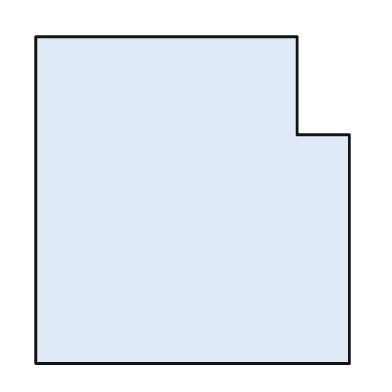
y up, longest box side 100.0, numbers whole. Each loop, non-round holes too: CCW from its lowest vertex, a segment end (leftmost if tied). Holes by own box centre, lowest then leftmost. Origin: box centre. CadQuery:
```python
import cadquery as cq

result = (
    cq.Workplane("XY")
    .moveTo(-48.0, -50.0)
    .lineTo(48.0, -50.0)
    .lineTo(48.0, 20.0)
    .lineTo(32.0, 20.0)
    .lineTo(32.0, 50.0)
    .lineTo(-48.0, 50.0)
    .close()
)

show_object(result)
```